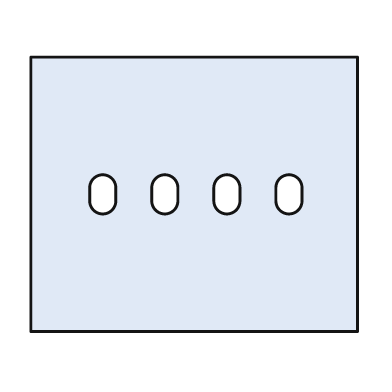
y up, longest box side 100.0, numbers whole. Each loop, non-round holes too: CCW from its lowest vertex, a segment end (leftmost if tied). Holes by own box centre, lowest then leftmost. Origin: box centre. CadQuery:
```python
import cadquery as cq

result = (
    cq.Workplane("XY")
    .moveTo(-50.0, -42.0)
    .lineTo(50.0, -42.0)
    .lineTo(50.0, 42.0)
    .lineTo(-50.0, 42.0)
    .close()
    .moveTo(-32.0, -2.0)
    .threePointArc((-28.0, -6.0), (-24.0, -2.0))
    .lineTo(-24.0, 2.0)
    .threePointArc((-28.0, 6.0), (-32.0, 2.0))
    .close()
    .moveTo(-13.0, -2.0)
    .threePointArc((-9.0, -6.0), (-5.0, -2.0))
    .lineTo(-5.0, 2.0)
    .threePointArc((-9.0, 6.0), (-13.0, 2.0))
    .close()
    .moveTo(6.0, -2.0)
    .threePointArc((10.0, -6.0), (14.0, -2.0))
    .lineTo(14.0, 2.0)
    .threePointArc((10.0, 6.0), (6.0, 2.0))
    .close()
    .moveTo(25.0, -2.0)
    .threePointArc((29.0, -6.0), (33.0, -2.0))
    .lineTo(33.0, 2.0)
    .threePointArc((29.0, 6.0), (25.0, 2.0))
    .close()
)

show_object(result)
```